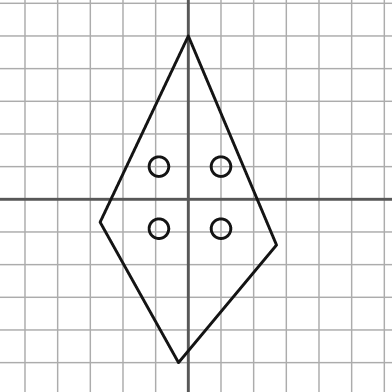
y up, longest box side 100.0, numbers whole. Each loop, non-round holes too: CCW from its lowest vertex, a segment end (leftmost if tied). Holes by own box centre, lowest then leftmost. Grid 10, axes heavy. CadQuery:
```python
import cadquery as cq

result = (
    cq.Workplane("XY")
    .moveTo(-3.0, -50.0)
    .lineTo(27.0, -14.0)
    .lineTo(0.0, 50.0)
    .lineTo(-27.0, -7.0)
    .close()
    .moveTo(-9.0, -9.0)
    .circle(3.0)
    .moveTo(10.0, -9.0)
    .circle(3.0)
    .moveTo(-9.0, 10.0)
    .circle(3.0)
    .moveTo(10.0, 10.0)
    .circle(3.0)
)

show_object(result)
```